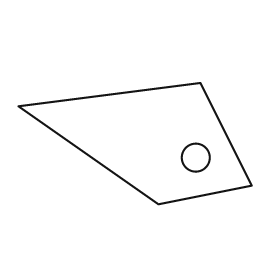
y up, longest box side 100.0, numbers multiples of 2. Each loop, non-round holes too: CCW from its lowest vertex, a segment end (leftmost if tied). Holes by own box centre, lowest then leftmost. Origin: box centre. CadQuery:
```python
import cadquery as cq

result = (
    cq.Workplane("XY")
    .moveTo(10.0, -26.0)
    .lineTo(50.0, -18.0)
    .lineTo(28.0, 26.0)
    .lineTo(-50.0, 16.0)
    .close()
    .moveTo(26.0, -6.0)
    .circle(6.0)
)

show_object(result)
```